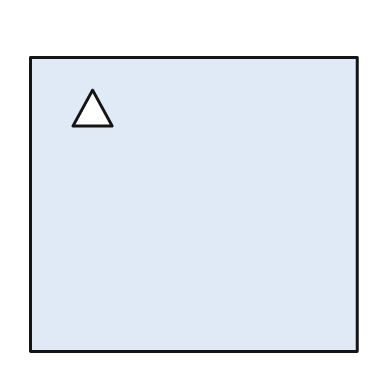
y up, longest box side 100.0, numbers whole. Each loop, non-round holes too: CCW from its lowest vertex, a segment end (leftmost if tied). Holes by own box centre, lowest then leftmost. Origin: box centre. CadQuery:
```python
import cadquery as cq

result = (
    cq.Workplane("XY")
    .moveTo(-50.0, -45.0)
    .lineTo(50.0, -45.0)
    .lineTo(50.0, 45.0)
    .lineTo(-50.0, 45.0)
    .close()
    .moveTo(-37.0, 24.0)
    .lineTo(-25.0, 24.0)
    .lineTo(-31.0, 35.0)
    .close()
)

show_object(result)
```